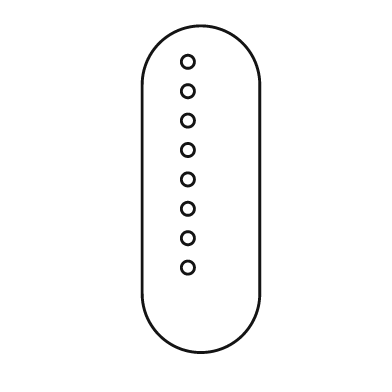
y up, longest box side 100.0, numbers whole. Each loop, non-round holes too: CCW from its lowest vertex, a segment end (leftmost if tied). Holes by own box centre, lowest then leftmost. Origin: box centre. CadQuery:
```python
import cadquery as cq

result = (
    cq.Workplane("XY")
    .moveTo(-18.0, -32.0)
    .threePointArc((0.0, -50.0), (18.0, -32.0))
    .lineTo(18.0, 32.0)
    .threePointArc((0.0, 50.0), (-18.0, 32.0))
    .close()
    .moveTo(-4.0, -24.0)
    .circle(2.0)
    .moveTo(-4.0, -15.0)
    .circle(2.0)
    .moveTo(-4.0, -6.0)
    .circle(2.0)
    .moveTo(-4.0, 3.0)
    .circle(2.0)
    .moveTo(-4.0, 12.0)
    .circle(2.0)
    .moveTo(-4.0, 21.0)
    .circle(2.0)
    .moveTo(-4.0, 30.0)
    .circle(2.0)
    .moveTo(-4.0, 39.0)
    .circle(2.0)
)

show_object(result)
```